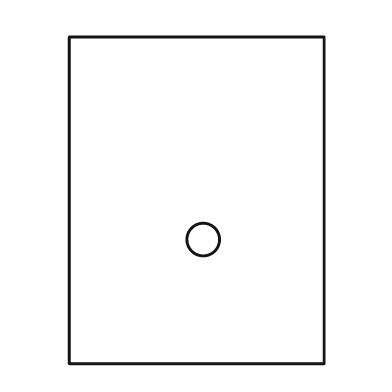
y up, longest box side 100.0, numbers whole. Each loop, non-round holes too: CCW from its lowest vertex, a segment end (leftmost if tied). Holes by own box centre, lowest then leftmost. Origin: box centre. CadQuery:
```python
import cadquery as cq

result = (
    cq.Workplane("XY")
    .moveTo(-39.0, -50.0)
    .lineTo(39.0, -50.0)
    .lineTo(39.0, 50.0)
    .lineTo(-39.0, 50.0)
    .close()
    .moveTo(2.0, -12.0)
    .circle(5.0)
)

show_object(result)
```